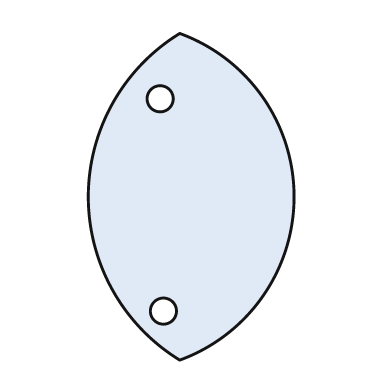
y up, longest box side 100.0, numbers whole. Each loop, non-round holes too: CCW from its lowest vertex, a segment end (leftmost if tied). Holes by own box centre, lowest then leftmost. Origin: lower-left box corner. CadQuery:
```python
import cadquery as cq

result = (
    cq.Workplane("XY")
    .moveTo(28.0, 0.0)
    .threePointArc((63.0, 50.0), (28.0, 100.0))
    .threePointArc((0.0, 50.0), (28.0, 0.0))
    .close()
    .moveTo(23.0, 15.0)
    .circle(4.0)
    .moveTo(22.0, 80.0)
    .circle(4.0)
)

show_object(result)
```